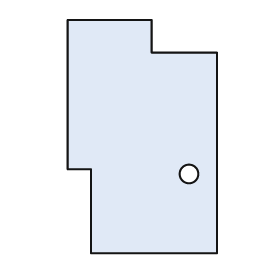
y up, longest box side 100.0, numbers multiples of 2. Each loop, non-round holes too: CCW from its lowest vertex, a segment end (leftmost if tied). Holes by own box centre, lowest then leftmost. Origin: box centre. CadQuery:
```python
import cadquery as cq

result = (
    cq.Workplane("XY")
    .moveTo(-22.0, -50.0)
    .lineTo(32.0, -50.0)
    .lineTo(32.0, 36.0)
    .lineTo(4.0, 36.0)
    .lineTo(4.0, 50.0)
    .lineTo(-32.0, 50.0)
    .lineTo(-32.0, -14.0)
    .lineTo(-22.0, -14.0)
    .close()
    .moveTo(20.0, -16.0)
    .circle(4.0)
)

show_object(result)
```